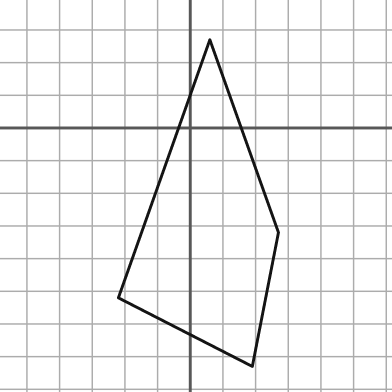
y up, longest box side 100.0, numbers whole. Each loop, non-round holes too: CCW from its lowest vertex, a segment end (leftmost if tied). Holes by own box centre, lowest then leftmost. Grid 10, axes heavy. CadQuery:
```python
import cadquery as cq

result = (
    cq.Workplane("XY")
    .moveTo(19.0, -73.0)
    .lineTo(27.0, -32.0)
    .lineTo(6.0, 27.0)
    .lineTo(-22.0, -52.0)
    .close()
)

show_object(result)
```